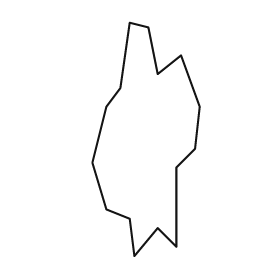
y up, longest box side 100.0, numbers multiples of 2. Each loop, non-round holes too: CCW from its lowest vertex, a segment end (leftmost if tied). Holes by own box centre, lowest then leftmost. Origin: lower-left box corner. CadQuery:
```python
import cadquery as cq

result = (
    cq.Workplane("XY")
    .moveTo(18.0, 0.0)
    .lineTo(28.0, 12.0)
    .lineTo(36.0, 4.0)
    .lineTo(36.0, 38.0)
    .lineTo(44.0, 46.0)
    .lineTo(46.0, 64.0)
    .lineTo(38.0, 86.0)
    .lineTo(28.0, 78.0)
    .lineTo(24.0, 98.0)
    .lineTo(16.0, 100.0)
    .lineTo(12.0, 72.0)
    .lineTo(6.0, 64.0)
    .lineTo(0.0, 40.0)
    .lineTo(6.0, 20.0)
    .lineTo(16.0, 16.0)
    .close()
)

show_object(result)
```